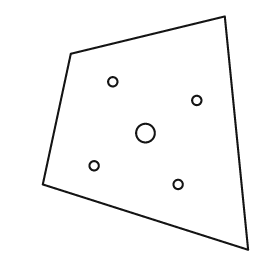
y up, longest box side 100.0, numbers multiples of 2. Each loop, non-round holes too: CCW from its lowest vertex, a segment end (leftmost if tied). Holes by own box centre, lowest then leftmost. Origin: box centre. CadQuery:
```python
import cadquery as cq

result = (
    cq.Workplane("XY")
    .moveTo(44.0, -50.0)
    .lineTo(34.0, 50.0)
    .lineTo(-32.0, 34.0)
    .lineTo(-44.0, -22.0)
    .close()
    .moveTo(14.0, -22.0)
    .circle(2.0)
    .moveTo(-22.0, -14.0)
    .circle(2.0)
    .moveTo(0.0, 0.0)
    .circle(4.0)
    .moveTo(22.0, 14.0)
    .circle(2.0)
    .moveTo(-14.0, 22.0)
    .circle(2.0)
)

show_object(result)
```